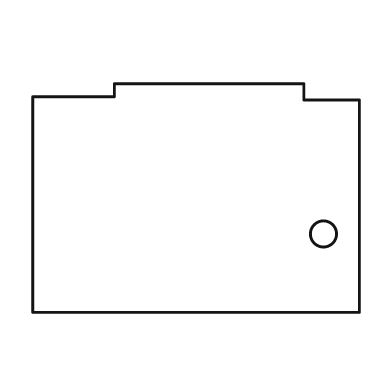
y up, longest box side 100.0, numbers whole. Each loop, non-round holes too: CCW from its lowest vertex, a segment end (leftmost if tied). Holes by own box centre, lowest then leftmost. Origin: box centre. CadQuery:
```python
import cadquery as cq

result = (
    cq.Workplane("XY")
    .moveTo(-50.0, -35.0)
    .lineTo(50.0, -35.0)
    .lineTo(50.0, 30.0)
    .lineTo(33.0, 30.0)
    .lineTo(33.0, 35.0)
    .lineTo(-25.0, 35.0)
    .lineTo(-25.0, 31.0)
    .lineTo(-50.0, 31.0)
    .close()
    .moveTo(39.0, -11.0)
    .circle(4.0)
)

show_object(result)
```